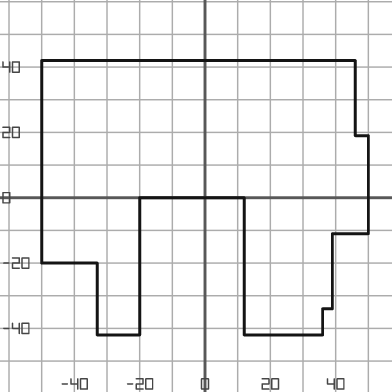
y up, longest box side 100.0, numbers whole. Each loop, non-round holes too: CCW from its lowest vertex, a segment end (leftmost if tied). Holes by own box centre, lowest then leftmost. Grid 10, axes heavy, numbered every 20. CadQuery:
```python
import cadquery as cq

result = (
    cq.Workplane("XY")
    .moveTo(-33.0, -42.0)
    .lineTo(-20.0, -42.0)
    .lineTo(-20.0, 0.0)
    .lineTo(12.0, 0.0)
    .lineTo(12.0, -42.0)
    .lineTo(36.0, -42.0)
    .lineTo(36.0, -34.0)
    .lineTo(39.0, -34.0)
    .lineTo(39.0, -11.0)
    .lineTo(50.0, -11.0)
    .lineTo(50.0, 19.0)
    .lineTo(46.0, 19.0)
    .lineTo(46.0, 42.0)
    .lineTo(-50.0, 42.0)
    .lineTo(-50.0, -20.0)
    .lineTo(-33.0, -20.0)
    .close()
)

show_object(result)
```